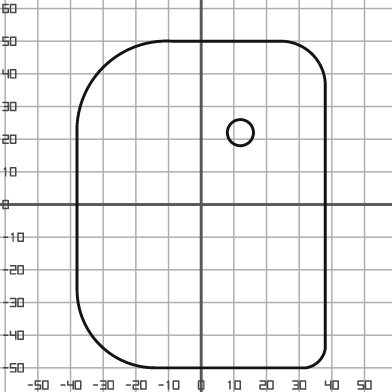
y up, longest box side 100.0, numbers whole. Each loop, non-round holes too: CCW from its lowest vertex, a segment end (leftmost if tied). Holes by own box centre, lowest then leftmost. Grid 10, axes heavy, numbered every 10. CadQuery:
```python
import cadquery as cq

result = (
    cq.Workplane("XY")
    .moveTo(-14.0, -50.0)
    .lineTo(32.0, -50.0)
    .threePointArc((36.0, -48.0), (38.0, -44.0))
    .lineTo(38.0, 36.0)
    .threePointArc((34.0, 46.0), (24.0, 50.0))
    .lineTo(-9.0, 50.0)
    .threePointArc((-30.0, 42.0), (-38.0, 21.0))
    .lineTo(-38.0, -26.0)
    .threePointArc((-31.0, -43.0), (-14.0, -50.0))
    .close()
    .moveTo(12.0, 22.0)
    .circle(4.0)
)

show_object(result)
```